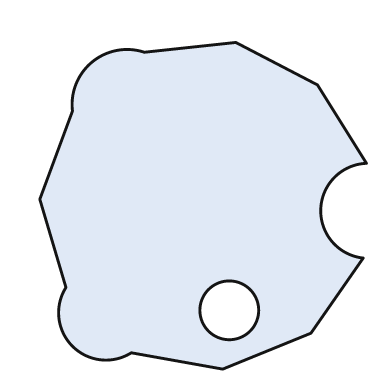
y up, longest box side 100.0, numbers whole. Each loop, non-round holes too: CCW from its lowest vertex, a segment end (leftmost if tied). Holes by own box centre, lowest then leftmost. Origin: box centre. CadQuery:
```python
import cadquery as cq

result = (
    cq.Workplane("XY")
    .moveTo(6.0, -50.0)
    .lineTo(33.0, -39.0)
    .lineTo(49.0, -16.0)
    .threePointArc((36.0, -1.0), (50.0, 13.0))
    .lineTo(35.0, 37.0)
    .lineTo(10.0, 50.0)
    .lineTo(-18.0, 47.0)
    .threePointArc((-34.0, 44.0), (-40.0, 29.0))
    .lineTo(-50.0, 2.0)
    .lineTo(-42.0, -25.0)
    .threePointArc((-40.0, -43.0), (-22.0, -45.0))
    .close()
    .moveTo(8.0, -32.0)
    .circle(9.0)
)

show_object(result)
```